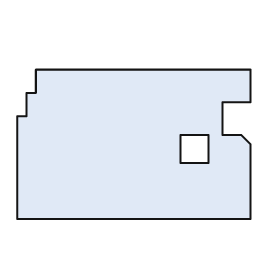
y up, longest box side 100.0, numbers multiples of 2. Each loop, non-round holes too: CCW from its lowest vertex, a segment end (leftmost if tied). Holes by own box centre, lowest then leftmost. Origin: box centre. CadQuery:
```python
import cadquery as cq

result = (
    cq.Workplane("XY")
    .moveTo(-50.0, -32.0)
    .lineTo(50.0, -32.0)
    .lineTo(50.0, 0.0)
    .lineTo(46.0, 4.0)
    .lineTo(38.0, 4.0)
    .lineTo(38.0, 18.0)
    .lineTo(50.0, 18.0)
    .lineTo(50.0, 32.0)
    .lineTo(-42.0, 32.0)
    .lineTo(-42.0, 22.0)
    .lineTo(-46.0, 22.0)
    .lineTo(-46.0, 12.0)
    .lineTo(-50.0, 12.0)
    .close()
    .moveTo(20.0, -8.0)
    .lineTo(32.0, -8.0)
    .lineTo(32.0, 4.0)
    .lineTo(20.0, 4.0)
    .close()
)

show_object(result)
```